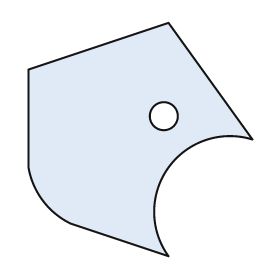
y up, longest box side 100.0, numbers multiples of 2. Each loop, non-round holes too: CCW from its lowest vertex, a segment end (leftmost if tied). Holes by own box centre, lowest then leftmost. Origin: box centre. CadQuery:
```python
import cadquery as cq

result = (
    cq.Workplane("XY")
    .moveTo(12.0, -50.0)
    .threePointArc((12.0, -12.0), (48.0, 0.0))
    .lineTo(12.0, 50.0)
    .lineTo(-48.0, 30.0)
    .lineTo(-48.0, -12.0)
    .threePointArc((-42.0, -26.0), (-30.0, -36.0))
    .close()
    .moveTo(10.0, 10.0)
    .circle(6.0)
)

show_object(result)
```